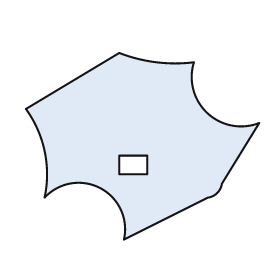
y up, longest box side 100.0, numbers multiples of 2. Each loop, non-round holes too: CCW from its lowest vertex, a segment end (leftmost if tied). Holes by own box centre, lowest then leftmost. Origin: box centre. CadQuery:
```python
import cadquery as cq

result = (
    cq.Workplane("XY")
    .moveTo(-8.0, -40.0)
    .lineTo(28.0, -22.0)
    .threePointArc((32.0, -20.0), (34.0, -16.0))
    .lineTo(50.0, 10.0)
    .threePointArc((28.0, 14.0), (22.0, 36.0))
    .threePointArc((6.0, 36.0), (-10.0, 40.0))
    .lineTo(-50.0, 16.0)
    .threePointArc((-42.0, -2.0), (-42.0, -22.0))
    .threePointArc((-18.0, -18.0), (-8.0, -40.0))
    .close()
    .moveTo(-10.0, -12.0)
    .lineTo(2.0, -12.0)
    .lineTo(2.0, -4.0)
    .lineTo(-10.0, -4.0)
    .close()
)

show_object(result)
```